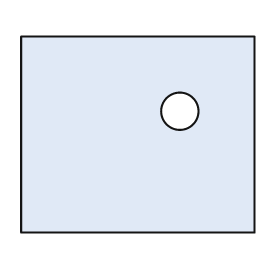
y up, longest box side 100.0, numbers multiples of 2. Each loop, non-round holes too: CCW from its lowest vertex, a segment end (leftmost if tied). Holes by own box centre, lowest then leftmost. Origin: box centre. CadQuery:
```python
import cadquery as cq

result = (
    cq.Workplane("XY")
    .moveTo(-50.0, -42.0)
    .lineTo(50.0, -42.0)
    .lineTo(50.0, 42.0)
    .lineTo(-50.0, 42.0)
    .close()
    .moveTo(18.0, 10.0)
    .circle(8.0)
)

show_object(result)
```